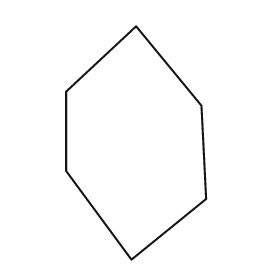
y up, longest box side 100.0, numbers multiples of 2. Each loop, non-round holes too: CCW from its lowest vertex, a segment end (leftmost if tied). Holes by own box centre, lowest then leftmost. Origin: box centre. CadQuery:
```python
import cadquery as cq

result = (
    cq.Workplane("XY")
    .moveTo(-2.0, -50.0)
    .lineTo(30.0, -24.0)
    .lineTo(28.0, 16.0)
    .lineTo(0.0, 50.0)
    .lineTo(-30.0, 22.0)
    .lineTo(-30.0, -12.0)
    .close()
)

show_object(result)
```